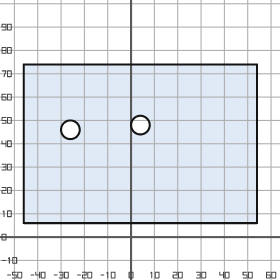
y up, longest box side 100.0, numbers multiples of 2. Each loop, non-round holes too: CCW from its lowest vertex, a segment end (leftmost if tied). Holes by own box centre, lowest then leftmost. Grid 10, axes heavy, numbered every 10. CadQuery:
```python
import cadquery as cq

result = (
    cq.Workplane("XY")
    .moveTo(-46.0, 6.0)
    .lineTo(54.0, 6.0)
    .lineTo(54.0, 74.0)
    .lineTo(-46.0, 74.0)
    .close()
    .moveTo(-26.0, 46.0)
    .circle(4.0)
    .moveTo(4.0, 48.0)
    .circle(4.0)
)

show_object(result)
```